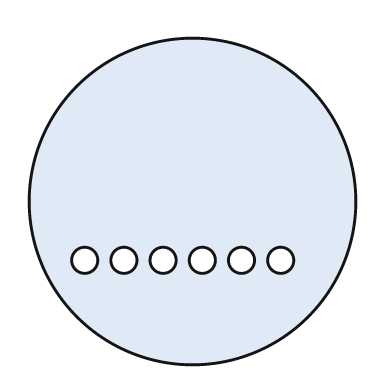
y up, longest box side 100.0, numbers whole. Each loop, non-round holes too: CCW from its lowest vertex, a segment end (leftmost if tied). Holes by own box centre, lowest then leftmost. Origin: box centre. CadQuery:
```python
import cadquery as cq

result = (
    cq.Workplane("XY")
    .moveTo(0.0, 0.0)
    .circle(50.0)
    .moveTo(-33.0, -18.0)
    .circle(4.0)
    .moveTo(-21.0, -18.0)
    .circle(4.0)
    .moveTo(-9.0, -18.0)
    .circle(4.0)
    .moveTo(3.0, -18.0)
    .circle(4.0)
    .moveTo(15.0, -18.0)
    .circle(4.0)
    .moveTo(27.0, -18.0)
    .circle(4.0)
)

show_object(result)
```